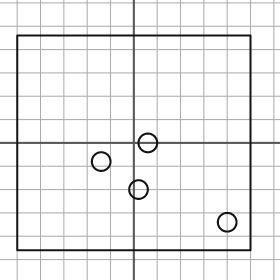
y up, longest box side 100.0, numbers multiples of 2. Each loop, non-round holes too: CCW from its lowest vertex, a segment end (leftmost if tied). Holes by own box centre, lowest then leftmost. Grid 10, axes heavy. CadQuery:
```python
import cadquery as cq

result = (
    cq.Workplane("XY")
    .moveTo(-50.0, -46.0)
    .lineTo(50.0, -46.0)
    .lineTo(50.0, 46.0)
    .lineTo(-50.0, 46.0)
    .close()
    .moveTo(40.0, -34.0)
    .circle(4.0)
    .moveTo(2.0, -20.0)
    .circle(4.0)
    .moveTo(-14.0, -8.0)
    .circle(4.0)
    .moveTo(6.0, 0.0)
    .circle(4.0)
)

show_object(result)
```